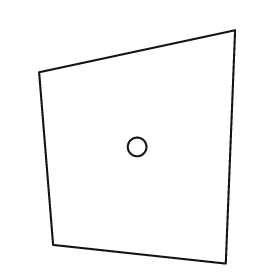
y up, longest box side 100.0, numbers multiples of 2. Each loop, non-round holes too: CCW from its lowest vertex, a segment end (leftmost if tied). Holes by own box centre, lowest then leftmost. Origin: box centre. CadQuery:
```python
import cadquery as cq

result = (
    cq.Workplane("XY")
    .moveTo(38.0, -50.0)
    .lineTo(42.0, 50.0)
    .lineTo(-42.0, 32.0)
    .lineTo(-36.0, -42.0)
    .close()
    .moveTo(0.0, 0.0)
    .circle(4.0)
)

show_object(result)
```